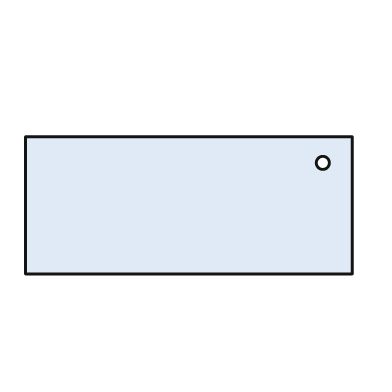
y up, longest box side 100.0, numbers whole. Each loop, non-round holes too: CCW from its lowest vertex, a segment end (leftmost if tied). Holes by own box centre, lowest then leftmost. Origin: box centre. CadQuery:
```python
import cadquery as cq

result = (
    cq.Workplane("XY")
    .moveTo(-50.0, -21.0)
    .lineTo(50.0, -21.0)
    .lineTo(50.0, 21.0)
    .lineTo(-50.0, 21.0)
    .close()
    .moveTo(41.0, 13.0)
    .circle(2.0)
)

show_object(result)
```